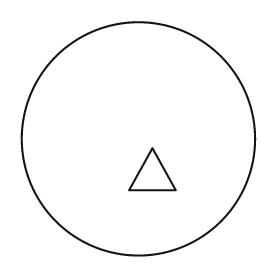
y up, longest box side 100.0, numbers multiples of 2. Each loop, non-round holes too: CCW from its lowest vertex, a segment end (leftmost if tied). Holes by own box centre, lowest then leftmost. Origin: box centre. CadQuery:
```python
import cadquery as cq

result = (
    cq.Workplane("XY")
    .moveTo(0.0, 0.0)
    .circle(50.0)
    .moveTo(-4.0, -22.0)
    .lineTo(16.0, -22.0)
    .lineTo(6.0, -4.0)
    .close()
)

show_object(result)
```